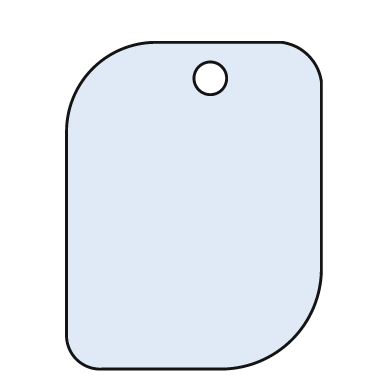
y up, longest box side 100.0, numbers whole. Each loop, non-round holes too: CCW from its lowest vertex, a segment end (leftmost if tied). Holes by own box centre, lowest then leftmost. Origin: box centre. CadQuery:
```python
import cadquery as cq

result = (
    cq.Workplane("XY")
    .moveTo(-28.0, -50.0)
    .lineTo(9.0, -50.0)
    .threePointArc((30.0, -41.0), (39.0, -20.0))
    .lineTo(39.0, 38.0)
    .threePointArc((35.0, 46.0), (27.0, 50.0))
    .lineTo(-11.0, 50.0)
    .threePointArc((-31.0, 42.0), (-39.0, 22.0))
    .lineTo(-39.0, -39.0)
    .threePointArc((-36.0, -47.0), (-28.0, -50.0))
    .close()
    .moveTo(5.0, 39.0)
    .circle(5.0)
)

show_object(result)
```